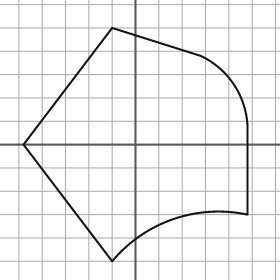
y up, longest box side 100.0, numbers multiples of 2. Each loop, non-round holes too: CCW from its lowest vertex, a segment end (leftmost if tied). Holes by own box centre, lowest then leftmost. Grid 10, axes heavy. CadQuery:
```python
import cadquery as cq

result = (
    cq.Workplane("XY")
    .moveTo(-10.0, -50.0)
    .threePointArc((16.0, -32.0), (48.0, -30.0))
    .lineTo(48.0, 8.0)
    .threePointArc((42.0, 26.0), (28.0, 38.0))
    .lineTo(-10.0, 50.0)
    .lineTo(-48.0, 0.0)
    .close()
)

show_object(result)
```